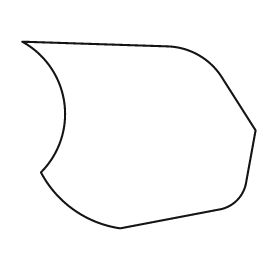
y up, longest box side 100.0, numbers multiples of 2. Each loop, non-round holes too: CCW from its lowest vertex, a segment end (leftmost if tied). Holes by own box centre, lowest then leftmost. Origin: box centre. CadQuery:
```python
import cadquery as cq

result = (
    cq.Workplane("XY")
    .moveTo(-8.0, -40.0)
    .lineTo(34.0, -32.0)
    .threePointArc((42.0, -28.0), (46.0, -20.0))
    .lineTo(50.0, 2.0)
    .lineTo(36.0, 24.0)
    .threePointArc((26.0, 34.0), (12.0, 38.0))
    .lineTo(-50.0, 40.0)
    .threePointArc((-32.0, 14.0), (-42.0, -16.0))
    .threePointArc((-28.0, -32.0), (-8.0, -40.0))
    .close()
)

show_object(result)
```